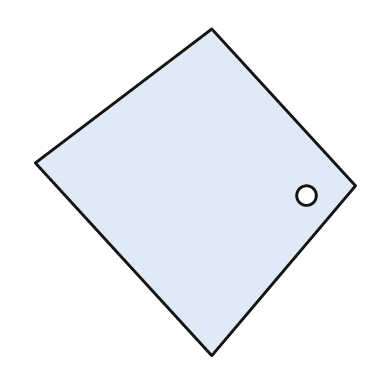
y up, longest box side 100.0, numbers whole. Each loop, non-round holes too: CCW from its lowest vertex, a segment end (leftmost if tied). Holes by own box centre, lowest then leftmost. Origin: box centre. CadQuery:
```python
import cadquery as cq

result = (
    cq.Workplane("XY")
    .moveTo(5.0, -50.0)
    .lineTo(49.0, 2.0)
    .lineTo(5.0, 50.0)
    .lineTo(-49.0, 9.0)
    .close()
    .moveTo(34.0, -1.0)
    .circle(3.0)
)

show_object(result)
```